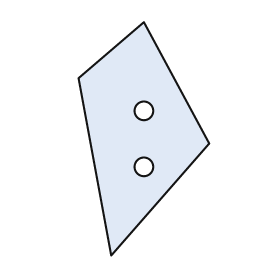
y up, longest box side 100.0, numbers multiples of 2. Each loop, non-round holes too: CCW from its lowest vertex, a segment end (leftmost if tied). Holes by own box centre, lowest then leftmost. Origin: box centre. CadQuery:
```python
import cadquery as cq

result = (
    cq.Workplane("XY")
    .moveTo(-14.0, -50.0)
    .lineTo(28.0, -2.0)
    .lineTo(0.0, 50.0)
    .lineTo(-28.0, 26.0)
    .close()
    .moveTo(0.0, -12.0)
    .circle(4.0)
    .moveTo(0.0, 12.0)
    .circle(4.0)
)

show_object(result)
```